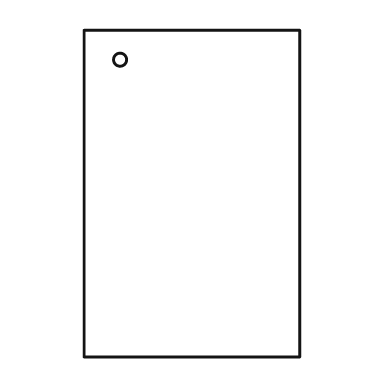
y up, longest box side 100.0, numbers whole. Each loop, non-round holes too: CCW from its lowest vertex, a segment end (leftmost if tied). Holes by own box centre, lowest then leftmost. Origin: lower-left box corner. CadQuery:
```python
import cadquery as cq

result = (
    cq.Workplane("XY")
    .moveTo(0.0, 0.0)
    .lineTo(66.0, 0.0)
    .lineTo(66.0, 100.0)
    .lineTo(0.0, 100.0)
    .close()
    .moveTo(11.0, 91.0)
    .circle(2.0)
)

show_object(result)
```